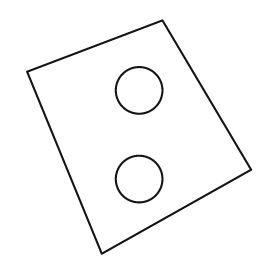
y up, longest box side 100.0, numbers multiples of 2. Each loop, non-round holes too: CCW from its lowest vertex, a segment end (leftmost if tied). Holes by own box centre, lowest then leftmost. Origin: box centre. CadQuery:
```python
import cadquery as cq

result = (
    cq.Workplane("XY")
    .moveTo(-16.0, -50.0)
    .lineTo(48.0, -14.0)
    .lineTo(10.0, 50.0)
    .lineTo(-48.0, 28.0)
    .close()
    .moveTo(0.0, -18.0)
    .circle(10.0)
    .moveTo(0.0, 20.0)
    .circle(10.0)
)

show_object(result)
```